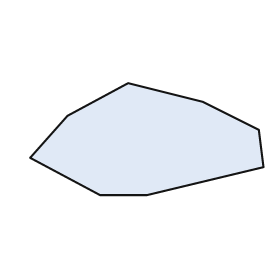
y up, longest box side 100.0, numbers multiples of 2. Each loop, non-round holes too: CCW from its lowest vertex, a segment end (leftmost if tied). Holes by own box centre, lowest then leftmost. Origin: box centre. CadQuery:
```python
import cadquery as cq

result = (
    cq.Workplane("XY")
    .moveTo(-20.0, -24.0)
    .lineTo(0.0, -24.0)
    .lineTo(50.0, -12.0)
    .lineTo(48.0, 4.0)
    .lineTo(24.0, 16.0)
    .lineTo(-8.0, 24.0)
    .lineTo(-34.0, 10.0)
    .lineTo(-50.0, -8.0)
    .close()
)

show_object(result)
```